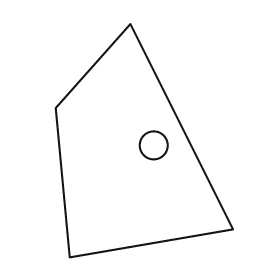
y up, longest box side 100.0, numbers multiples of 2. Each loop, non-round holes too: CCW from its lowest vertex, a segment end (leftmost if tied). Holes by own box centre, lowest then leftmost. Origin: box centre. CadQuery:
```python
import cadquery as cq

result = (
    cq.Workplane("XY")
    .moveTo(-32.0, -50.0)
    .lineTo(38.0, -38.0)
    .lineTo(-6.0, 50.0)
    .lineTo(-38.0, 14.0)
    .close()
    .moveTo(4.0, -2.0)
    .circle(6.0)
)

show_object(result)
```